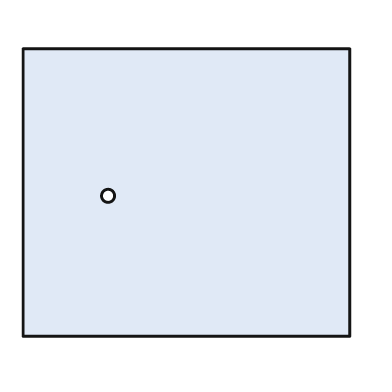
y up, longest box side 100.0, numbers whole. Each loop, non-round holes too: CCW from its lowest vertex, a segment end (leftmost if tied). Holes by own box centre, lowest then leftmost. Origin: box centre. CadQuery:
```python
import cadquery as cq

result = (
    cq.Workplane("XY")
    .moveTo(-50.0, -44.0)
    .lineTo(50.0, -44.0)
    .lineTo(50.0, 44.0)
    .lineTo(-50.0, 44.0)
    .close()
    .moveTo(-24.0, -1.0)
    .circle(2.0)
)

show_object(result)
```